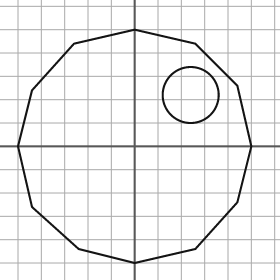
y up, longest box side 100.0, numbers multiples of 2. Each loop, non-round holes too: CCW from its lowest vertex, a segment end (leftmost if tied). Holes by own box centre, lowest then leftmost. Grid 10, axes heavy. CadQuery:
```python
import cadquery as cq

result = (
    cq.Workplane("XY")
    .moveTo(0.0, -50.0)
    .lineTo(26.0, -44.0)
    .lineTo(44.0, -24.0)
    .lineTo(50.0, 0.0)
    .lineTo(44.0, 26.0)
    .lineTo(26.0, 44.0)
    .lineTo(0.0, 50.0)
    .lineTo(-26.0, 44.0)
    .lineTo(-44.0, 24.0)
    .lineTo(-50.0, 0.0)
    .lineTo(-44.0, -26.0)
    .lineTo(-24.0, -44.0)
    .close()
    .moveTo(24.0, 22.0)
    .circle(12.0)
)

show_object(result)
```